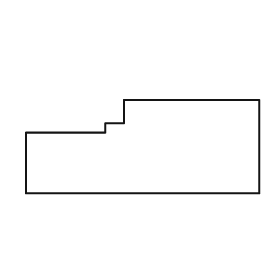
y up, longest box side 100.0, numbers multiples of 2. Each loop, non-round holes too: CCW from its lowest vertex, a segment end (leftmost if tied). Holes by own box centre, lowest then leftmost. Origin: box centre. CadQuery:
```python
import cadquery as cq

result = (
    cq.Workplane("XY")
    .moveTo(-50.0, -20.0)
    .lineTo(50.0, -20.0)
    .lineTo(50.0, 20.0)
    .lineTo(-8.0, 20.0)
    .lineTo(-8.0, 10.0)
    .lineTo(-16.0, 10.0)
    .lineTo(-16.0, 6.0)
    .lineTo(-50.0, 6.0)
    .close()
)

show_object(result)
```